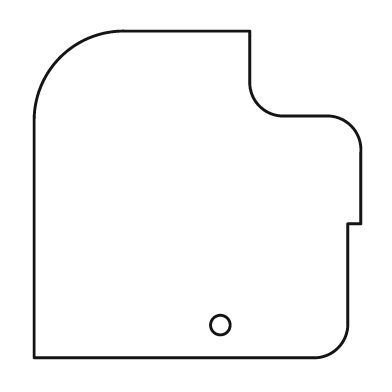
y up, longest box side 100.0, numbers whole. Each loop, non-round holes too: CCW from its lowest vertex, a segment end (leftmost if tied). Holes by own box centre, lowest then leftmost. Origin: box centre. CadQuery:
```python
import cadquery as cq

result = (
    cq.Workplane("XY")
    .moveTo(-50.0, -50.0)
    .lineTo(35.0, -50.0)
    .threePointArc((43.0, -47.0), (46.0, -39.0))
    .lineTo(46.0, -9.0)
    .lineTo(50.0, -9.0)
    .lineTo(50.0, 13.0)
    .threePointArc((47.0, 21.0), (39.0, 24.0))
    .lineTo(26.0, 24.0)
    .threePointArc((19.0, 27.0), (16.0, 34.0))
    .lineTo(16.0, 50.0)
    .lineTo(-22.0, 50.0)
    .threePointArc((-42.0, 42.0), (-50.0, 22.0))
    .close()
    .moveTo(7.0, -40.0)
    .circle(3.0)
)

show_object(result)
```